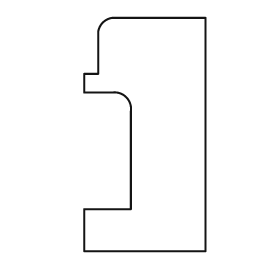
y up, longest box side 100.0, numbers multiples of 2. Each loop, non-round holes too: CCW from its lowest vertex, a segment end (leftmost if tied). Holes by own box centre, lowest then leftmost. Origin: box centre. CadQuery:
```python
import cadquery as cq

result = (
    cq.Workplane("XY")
    .moveTo(-26.0, -50.0)
    .lineTo(26.0, -50.0)
    .lineTo(26.0, 50.0)
    .lineTo(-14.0, 50.0)
    .threePointArc((-18.0, 48.0), (-20.0, 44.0))
    .lineTo(-20.0, 26.0)
    .lineTo(-26.0, 26.0)
    .lineTo(-26.0, 18.0)
    .lineTo(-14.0, 18.0)
    .threePointArc((-8.0, 16.0), (-6.0, 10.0))
    .lineTo(-6.0, -32.0)
    .lineTo(-26.0, -32.0)
    .close()
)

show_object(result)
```